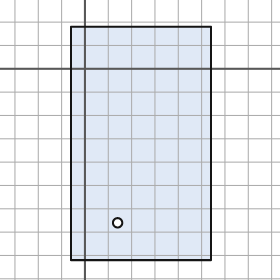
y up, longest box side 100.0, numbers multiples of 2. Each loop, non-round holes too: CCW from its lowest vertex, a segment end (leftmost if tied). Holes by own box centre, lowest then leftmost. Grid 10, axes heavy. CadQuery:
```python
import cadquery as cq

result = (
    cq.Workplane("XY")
    .moveTo(-6.0, -82.0)
    .lineTo(54.0, -82.0)
    .lineTo(54.0, 18.0)
    .lineTo(-6.0, 18.0)
    .close()
    .moveTo(14.0, -66.0)
    .circle(2.0)
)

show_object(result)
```